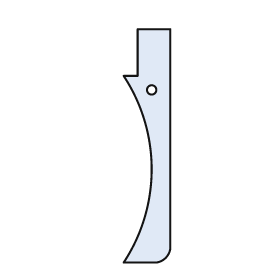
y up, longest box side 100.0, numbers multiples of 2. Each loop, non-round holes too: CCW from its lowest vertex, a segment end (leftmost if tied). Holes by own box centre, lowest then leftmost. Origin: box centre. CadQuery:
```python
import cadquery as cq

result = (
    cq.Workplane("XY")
    .moveTo(-10.0, -50.0)
    .lineTo(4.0, -50.0)
    .threePointArc((8.0, -48.0), (10.0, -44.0))
    .lineTo(10.0, 50.0)
    .lineTo(-4.0, 50.0)
    .lineTo(-4.0, 30.0)
    .lineTo(-10.0, 30.0)
    .threePointArc((2.0, -10.0), (-10.0, -50.0))
    .close()
    .moveTo(2.0, 24.0)
    .circle(2.0)
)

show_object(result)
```